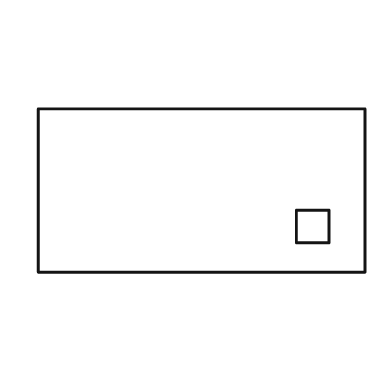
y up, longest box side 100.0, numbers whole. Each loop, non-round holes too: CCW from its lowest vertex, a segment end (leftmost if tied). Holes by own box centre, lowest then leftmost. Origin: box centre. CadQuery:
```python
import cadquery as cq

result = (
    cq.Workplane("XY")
    .moveTo(-50.0, -25.0)
    .lineTo(50.0, -25.0)
    .lineTo(50.0, 25.0)
    .lineTo(-50.0, 25.0)
    .close()
    .moveTo(29.0, -16.0)
    .lineTo(39.0, -16.0)
    .lineTo(39.0, -6.0)
    .lineTo(29.0, -6.0)
    .close()
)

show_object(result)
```